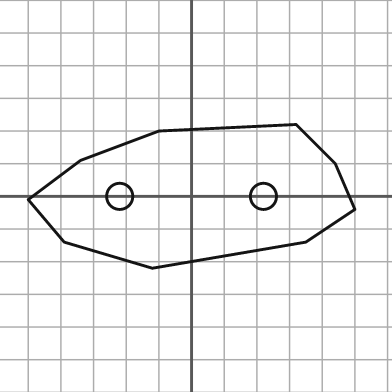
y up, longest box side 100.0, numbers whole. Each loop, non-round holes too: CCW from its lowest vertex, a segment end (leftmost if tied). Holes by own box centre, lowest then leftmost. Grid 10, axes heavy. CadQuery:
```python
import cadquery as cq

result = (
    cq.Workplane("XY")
    .moveTo(-12.0, -22.0)
    .lineTo(35.0, -14.0)
    .lineTo(50.0, -4.0)
    .lineTo(44.0, 10.0)
    .lineTo(32.0, 22.0)
    .lineTo(-10.0, 20.0)
    .lineTo(-34.0, 11.0)
    .lineTo(-50.0, -1.0)
    .lineTo(-39.0, -14.0)
    .close()
    .moveTo(-22.0, 0.0)
    .circle(4.0)
    .moveTo(22.0, 0.0)
    .circle(4.0)
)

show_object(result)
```